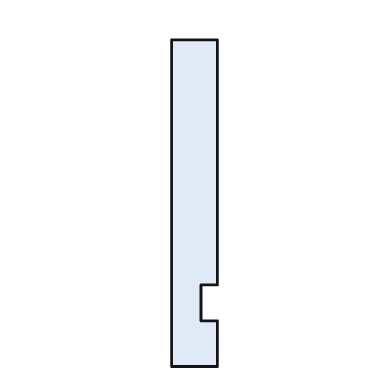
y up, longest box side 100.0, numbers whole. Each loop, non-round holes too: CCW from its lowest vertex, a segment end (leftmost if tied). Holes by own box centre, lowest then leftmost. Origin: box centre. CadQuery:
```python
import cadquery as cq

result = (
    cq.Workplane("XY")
    .moveTo(-7.0, -50.0)
    .lineTo(7.0, -50.0)
    .lineTo(7.0, -36.0)
    .lineTo(2.0, -36.0)
    .lineTo(2.0, -25.0)
    .lineTo(7.0, -25.0)
    .lineTo(7.0, 50.0)
    .lineTo(-7.0, 50.0)
    .close()
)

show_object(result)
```